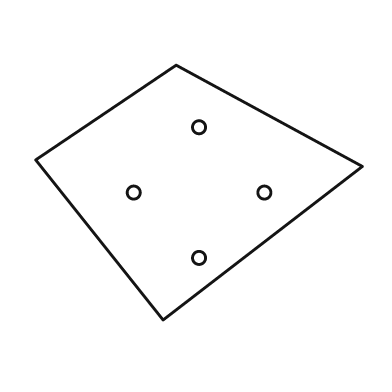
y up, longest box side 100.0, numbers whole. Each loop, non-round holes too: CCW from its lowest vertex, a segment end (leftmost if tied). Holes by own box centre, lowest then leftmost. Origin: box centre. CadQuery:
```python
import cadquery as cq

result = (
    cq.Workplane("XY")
    .moveTo(-11.0, -39.0)
    .lineTo(50.0, 8.0)
    .lineTo(-7.0, 39.0)
    .lineTo(-50.0, 10.0)
    .close()
    .moveTo(0.0, -20.0)
    .circle(2.0)
    .moveTo(-20.0, 0.0)
    .circle(2.0)
    .moveTo(20.0, 0.0)
    .circle(2.0)
    .moveTo(0.0, 20.0)
    .circle(2.0)
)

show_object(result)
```